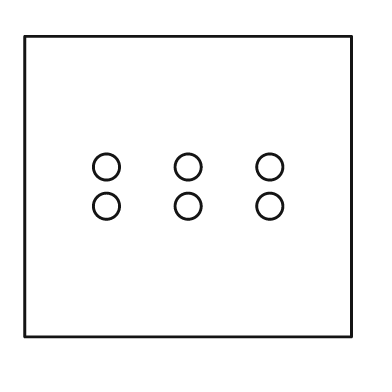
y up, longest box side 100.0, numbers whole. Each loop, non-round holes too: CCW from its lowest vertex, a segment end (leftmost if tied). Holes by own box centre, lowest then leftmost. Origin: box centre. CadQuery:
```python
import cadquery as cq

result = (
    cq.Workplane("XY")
    .moveTo(-50.0, -46.0)
    .lineTo(50.0, -46.0)
    .lineTo(50.0, 46.0)
    .lineTo(-50.0, 46.0)
    .close()
    .moveTo(-25.0, -6.0)
    .circle(4.0)
    .moveTo(0.0, -6.0)
    .circle(4.0)
    .moveTo(25.0, -6.0)
    .circle(4.0)
    .moveTo(-25.0, 6.0)
    .circle(4.0)
    .moveTo(0.0, 6.0)
    .circle(4.0)
    .moveTo(25.0, 6.0)
    .circle(4.0)
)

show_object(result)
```